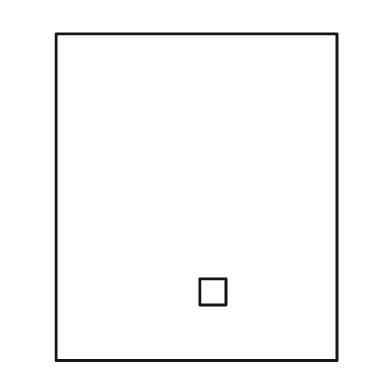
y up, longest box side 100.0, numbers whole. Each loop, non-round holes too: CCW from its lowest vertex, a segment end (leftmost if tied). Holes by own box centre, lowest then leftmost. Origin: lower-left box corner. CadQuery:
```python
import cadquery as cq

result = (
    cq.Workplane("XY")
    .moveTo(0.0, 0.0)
    .lineTo(86.0, 0.0)
    .lineTo(86.0, 100.0)
    .lineTo(0.0, 100.0)
    .close()
    .moveTo(44.0, 17.0)
    .lineTo(52.0, 17.0)
    .lineTo(52.0, 25.0)
    .lineTo(44.0, 25.0)
    .close()
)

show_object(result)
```